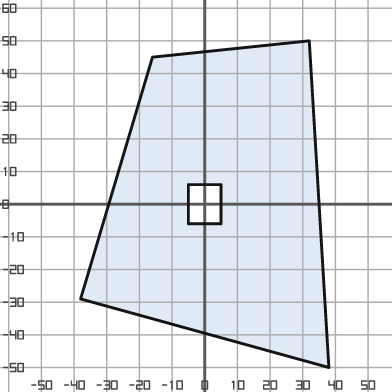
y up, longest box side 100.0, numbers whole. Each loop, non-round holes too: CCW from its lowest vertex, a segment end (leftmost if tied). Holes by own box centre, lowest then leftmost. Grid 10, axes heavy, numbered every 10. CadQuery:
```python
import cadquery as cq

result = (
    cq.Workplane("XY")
    .moveTo(38.0, -50.0)
    .lineTo(32.0, 50.0)
    .lineTo(-16.0, 45.0)
    .lineTo(-38.0, -29.0)
    .close()
    .moveTo(-5.0, -6.0)
    .lineTo(5.0, -6.0)
    .lineTo(5.0, 6.0)
    .lineTo(-5.0, 6.0)
    .close()
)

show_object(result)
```